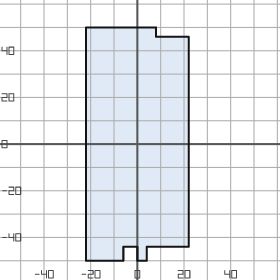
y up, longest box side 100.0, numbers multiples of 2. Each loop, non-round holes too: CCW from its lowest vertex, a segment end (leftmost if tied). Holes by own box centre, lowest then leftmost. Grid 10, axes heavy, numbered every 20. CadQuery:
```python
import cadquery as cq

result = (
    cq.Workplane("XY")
    .moveTo(-22.0, -50.0)
    .lineTo(-6.0, -50.0)
    .lineTo(-6.0, -44.0)
    .lineTo(0.0, -44.0)
    .lineTo(0.0, -50.0)
    .lineTo(4.0, -50.0)
    .lineTo(4.0, -44.0)
    .lineTo(22.0, -44.0)
    .lineTo(22.0, 46.0)
    .lineTo(8.0, 46.0)
    .lineTo(8.0, 50.0)
    .lineTo(-22.0, 50.0)
    .close()
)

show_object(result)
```